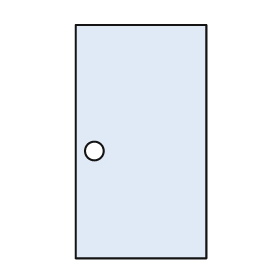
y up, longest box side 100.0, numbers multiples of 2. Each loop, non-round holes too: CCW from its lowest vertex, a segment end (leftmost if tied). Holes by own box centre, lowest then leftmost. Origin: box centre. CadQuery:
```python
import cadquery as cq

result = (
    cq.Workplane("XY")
    .moveTo(-28.0, -50.0)
    .lineTo(28.0, -50.0)
    .lineTo(28.0, 50.0)
    .lineTo(-28.0, 50.0)
    .close()
    .moveTo(-20.0, -4.0)
    .circle(4.0)
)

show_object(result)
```